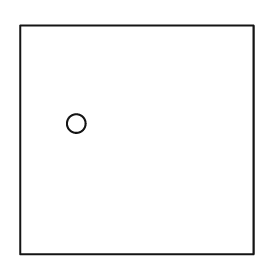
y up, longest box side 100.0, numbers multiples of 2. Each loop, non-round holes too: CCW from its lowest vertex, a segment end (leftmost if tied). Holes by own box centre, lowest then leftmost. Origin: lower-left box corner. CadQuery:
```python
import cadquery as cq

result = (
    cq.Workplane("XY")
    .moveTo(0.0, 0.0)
    .lineTo(100.0, 0.0)
    .lineTo(100.0, 98.0)
    .lineTo(0.0, 98.0)
    .close()
    .moveTo(24.0, 56.0)
    .circle(4.0)
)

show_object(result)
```